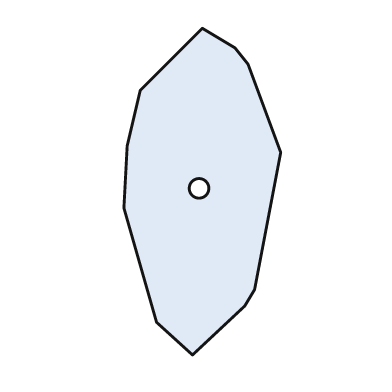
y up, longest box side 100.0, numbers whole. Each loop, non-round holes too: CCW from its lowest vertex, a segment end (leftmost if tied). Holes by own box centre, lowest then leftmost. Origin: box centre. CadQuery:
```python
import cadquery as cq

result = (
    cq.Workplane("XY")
    .moveTo(-3.0, -50.0)
    .lineTo(13.0, -35.0)
    .lineTo(16.0, -30.0)
    .lineTo(24.0, 12.0)
    .lineTo(14.0, 39.0)
    .lineTo(10.0, 44.0)
    .lineTo(0.0, 50.0)
    .lineTo(-19.0, 31.0)
    .lineTo(-23.0, 14.0)
    .lineTo(-24.0, -5.0)
    .lineTo(-14.0, -40.0)
    .close()
    .moveTo(-1.0, 1.0)
    .circle(3.0)
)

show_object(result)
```